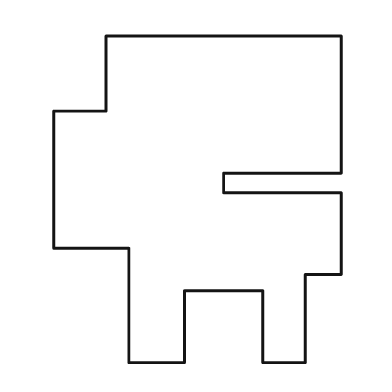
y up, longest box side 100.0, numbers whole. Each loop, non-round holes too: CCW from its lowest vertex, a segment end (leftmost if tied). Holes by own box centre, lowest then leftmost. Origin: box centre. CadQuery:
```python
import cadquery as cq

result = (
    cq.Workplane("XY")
    .moveTo(-21.0, -50.0)
    .lineTo(-4.0, -50.0)
    .lineTo(-4.0, -28.0)
    .lineTo(20.0, -28.0)
    .lineTo(20.0, -50.0)
    .lineTo(33.0, -50.0)
    .lineTo(33.0, -23.0)
    .lineTo(44.0, -23.0)
    .lineTo(44.0, 2.0)
    .lineTo(8.0, 2.0)
    .lineTo(8.0, 8.0)
    .lineTo(44.0, 8.0)
    .lineTo(44.0, 50.0)
    .lineTo(-28.0, 50.0)
    .lineTo(-28.0, 27.0)
    .lineTo(-44.0, 27.0)
    .lineTo(-44.0, -15.0)
    .lineTo(-21.0, -15.0)
    .close()
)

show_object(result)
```